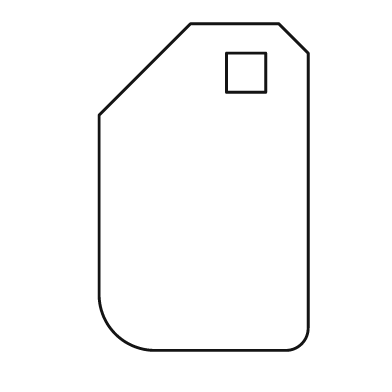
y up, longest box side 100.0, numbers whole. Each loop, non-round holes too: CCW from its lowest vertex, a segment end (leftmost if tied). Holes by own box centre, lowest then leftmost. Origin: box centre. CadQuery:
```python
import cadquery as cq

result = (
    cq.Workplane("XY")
    .moveTo(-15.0, -50.0)
    .lineTo(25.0, -50.0)
    .threePointArc((30.0, -48.0), (32.0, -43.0))
    .lineTo(32.0, 41.0)
    .lineTo(23.0, 50.0)
    .lineTo(-4.0, 50.0)
    .lineTo(-32.0, 22.0)
    .lineTo(-32.0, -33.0)
    .threePointArc((-27.0, -45.0), (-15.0, -50.0))
    .close()
    .moveTo(7.0, 29.0)
    .lineTo(19.0, 29.0)
    .lineTo(19.0, 41.0)
    .lineTo(7.0, 41.0)
    .close()
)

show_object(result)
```